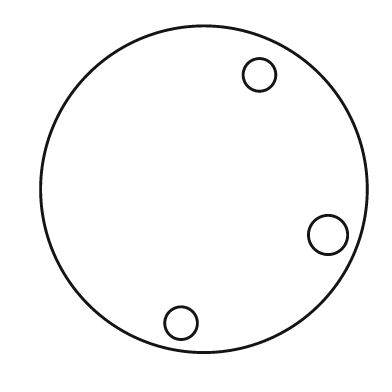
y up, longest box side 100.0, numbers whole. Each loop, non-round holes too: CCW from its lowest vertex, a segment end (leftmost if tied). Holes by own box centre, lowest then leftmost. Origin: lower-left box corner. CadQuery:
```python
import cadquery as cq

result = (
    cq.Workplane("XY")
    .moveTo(50.0, 50.0)
    .circle(50.0)
    .moveTo(43.0, 9.0)
    .circle(5.0)
    .moveTo(88.0, 36.0)
    .circle(6.0)
    .moveTo(67.0, 85.0)
    .circle(5.0)
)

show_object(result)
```